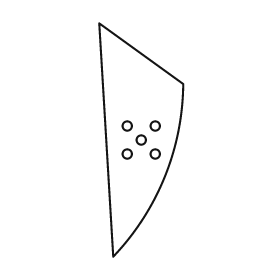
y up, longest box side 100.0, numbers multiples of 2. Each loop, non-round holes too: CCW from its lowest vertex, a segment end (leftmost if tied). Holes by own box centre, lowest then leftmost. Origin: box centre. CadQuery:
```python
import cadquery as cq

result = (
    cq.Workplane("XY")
    .moveTo(-12.0, -50.0)
    .threePointArc((10.0, -16.0), (18.0, 24.0))
    .lineTo(-18.0, 50.0)
    .close()
    .moveTo(-6.0, -6.0)
    .circle(2.0)
    .moveTo(6.0, -6.0)
    .circle(2.0)
    .moveTo(0.0, 0.0)
    .circle(2.0)
    .moveTo(-6.0, 6.0)
    .circle(2.0)
    .moveTo(6.0, 6.0)
    .circle(2.0)
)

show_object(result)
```